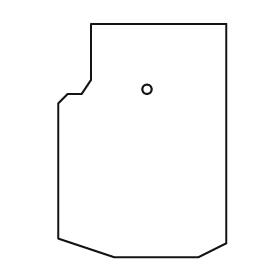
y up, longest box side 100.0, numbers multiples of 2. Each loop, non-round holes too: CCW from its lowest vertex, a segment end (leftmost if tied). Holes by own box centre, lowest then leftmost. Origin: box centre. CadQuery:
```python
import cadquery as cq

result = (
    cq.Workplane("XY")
    .moveTo(-12.0, -50.0)
    .lineTo(24.0, -50.0)
    .lineTo(36.0, -44.0)
    .lineTo(36.0, 50.0)
    .lineTo(-22.0, 50.0)
    .lineTo(-22.0, 26.0)
    .lineTo(-26.0, 20.0)
    .lineTo(-32.0, 20.0)
    .lineTo(-36.0, 16.0)
    .lineTo(-36.0, -42.0)
    .close()
    .moveTo(2.0, 22.0)
    .circle(2.0)
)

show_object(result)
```